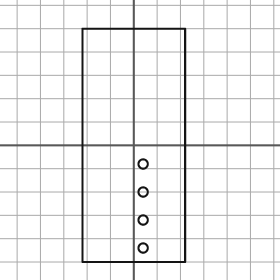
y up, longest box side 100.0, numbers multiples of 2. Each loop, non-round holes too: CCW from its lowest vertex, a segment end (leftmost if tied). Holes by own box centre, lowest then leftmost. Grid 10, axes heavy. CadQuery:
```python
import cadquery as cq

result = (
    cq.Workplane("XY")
    .moveTo(-22.0, -50.0)
    .lineTo(22.0, -50.0)
    .lineTo(22.0, 50.0)
    .lineTo(-22.0, 50.0)
    .close()
    .moveTo(4.0, -44.0)
    .circle(2.0)
    .moveTo(4.0, -32.0)
    .circle(2.0)
    .moveTo(4.0, -20.0)
    .circle(2.0)
    .moveTo(4.0, -8.0)
    .circle(2.0)
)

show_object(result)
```